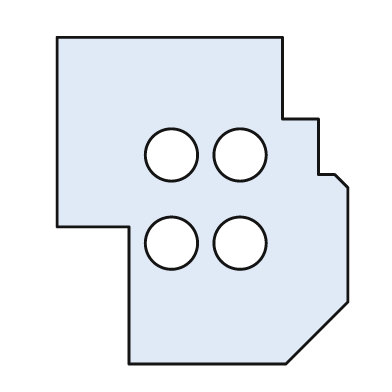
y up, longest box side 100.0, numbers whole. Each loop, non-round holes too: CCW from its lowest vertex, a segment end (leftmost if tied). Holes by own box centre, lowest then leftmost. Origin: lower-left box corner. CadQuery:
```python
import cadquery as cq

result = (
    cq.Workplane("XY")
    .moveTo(22.0, 0.0)
    .lineTo(70.0, 0.0)
    .lineTo(89.0, 19.0)
    .lineTo(89.0, 54.0)
    .lineTo(85.0, 58.0)
    .lineTo(80.0, 58.0)
    .lineTo(80.0, 75.0)
    .lineTo(69.0, 75.0)
    .lineTo(69.0, 100.0)
    .lineTo(0.0, 100.0)
    .lineTo(0.0, 42.0)
    .lineTo(22.0, 42.0)
    .close()
    .moveTo(35.0, 37.0)
    .circle(8.0)
    .moveTo(56.0, 37.0)
    .circle(8.0)
    .moveTo(35.0, 64.0)
    .circle(8.0)
    .moveTo(56.0, 64.0)
    .circle(8.0)
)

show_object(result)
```